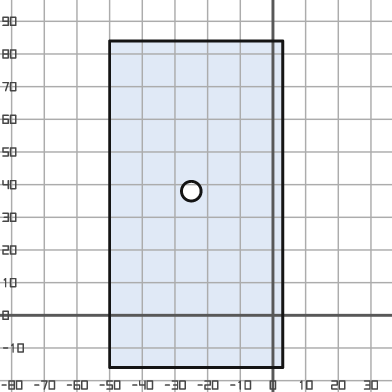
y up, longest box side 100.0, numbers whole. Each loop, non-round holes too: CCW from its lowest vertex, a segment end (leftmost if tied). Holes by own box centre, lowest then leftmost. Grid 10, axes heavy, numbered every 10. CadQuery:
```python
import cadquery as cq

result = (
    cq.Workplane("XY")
    .moveTo(-50.0, -16.0)
    .lineTo(3.0, -16.0)
    .lineTo(3.0, 84.0)
    .lineTo(-50.0, 84.0)
    .close()
    .moveTo(-25.0, 38.0)
    .circle(3.0)
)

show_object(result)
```